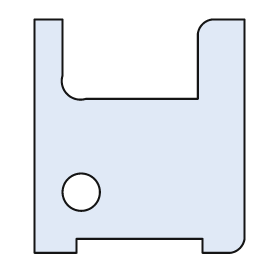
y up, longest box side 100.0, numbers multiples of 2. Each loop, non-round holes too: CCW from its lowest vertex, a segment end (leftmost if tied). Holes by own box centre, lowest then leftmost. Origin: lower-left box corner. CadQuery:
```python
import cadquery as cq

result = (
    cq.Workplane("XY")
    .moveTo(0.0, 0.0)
    .lineTo(18.0, 0.0)
    .lineTo(18.0, 6.0)
    .lineTo(72.0, 6.0)
    .lineTo(72.0, 0.0)
    .lineTo(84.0, 0.0)
    .threePointArc((88.0, 2.0), (90.0, 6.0))
    .lineTo(90.0, 100.0)
    .lineTo(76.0, 100.0)
    .threePointArc((72.0, 98.0), (70.0, 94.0))
    .lineTo(70.0, 66.0)
    .lineTo(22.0, 66.0)
    .threePointArc((14.0, 68.0), (12.0, 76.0))
    .lineTo(12.0, 100.0)
    .lineTo(0.0, 100.0)
    .close()
    .moveTo(20.0, 26.0)
    .circle(8.0)
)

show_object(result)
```